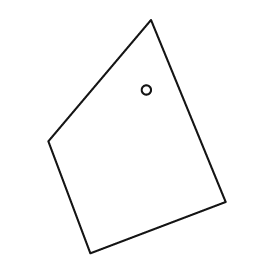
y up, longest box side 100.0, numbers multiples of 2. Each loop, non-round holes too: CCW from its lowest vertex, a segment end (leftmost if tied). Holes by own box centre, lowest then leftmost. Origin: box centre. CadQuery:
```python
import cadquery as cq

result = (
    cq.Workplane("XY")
    .moveTo(-20.0, -50.0)
    .lineTo(38.0, -28.0)
    .lineTo(6.0, 50.0)
    .lineTo(-38.0, -2.0)
    .close()
    .moveTo(4.0, 20.0)
    .circle(2.0)
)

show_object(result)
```